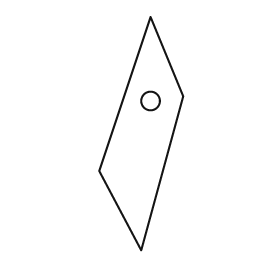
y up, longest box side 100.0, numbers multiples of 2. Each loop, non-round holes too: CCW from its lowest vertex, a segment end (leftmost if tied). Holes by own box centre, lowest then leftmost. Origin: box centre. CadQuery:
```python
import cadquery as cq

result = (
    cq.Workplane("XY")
    .moveTo(0.0, -50.0)
    .lineTo(18.0, 16.0)
    .lineTo(4.0, 50.0)
    .lineTo(-18.0, -16.0)
    .close()
    .moveTo(4.0, 14.0)
    .circle(4.0)
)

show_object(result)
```